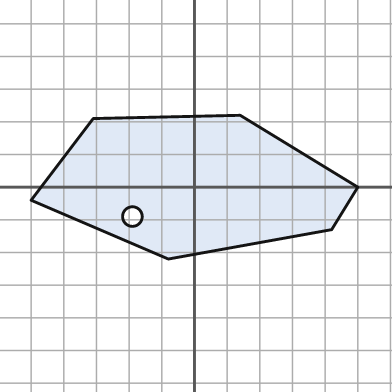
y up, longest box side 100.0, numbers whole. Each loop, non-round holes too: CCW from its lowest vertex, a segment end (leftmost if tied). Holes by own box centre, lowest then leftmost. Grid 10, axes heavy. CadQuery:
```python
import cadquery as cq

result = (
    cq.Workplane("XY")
    .moveTo(-8.0, -22.0)
    .lineTo(42.0, -13.0)
    .lineTo(50.0, 0.0)
    .lineTo(14.0, 22.0)
    .lineTo(-31.0, 21.0)
    .lineTo(-50.0, -4.0)
    .close()
    .moveTo(-19.0, -9.0)
    .circle(3.0)
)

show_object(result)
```